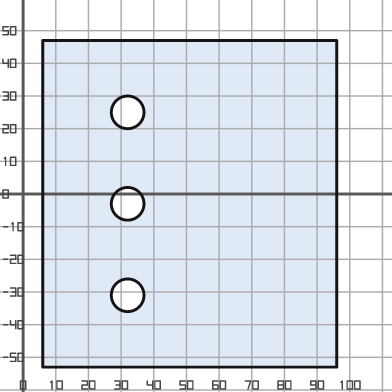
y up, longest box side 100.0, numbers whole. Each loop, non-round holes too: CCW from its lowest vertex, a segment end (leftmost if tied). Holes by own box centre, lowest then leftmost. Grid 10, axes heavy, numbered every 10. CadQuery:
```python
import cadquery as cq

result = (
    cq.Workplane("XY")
    .moveTo(6.0, -53.0)
    .lineTo(96.0, -53.0)
    .lineTo(96.0, 47.0)
    .lineTo(6.0, 47.0)
    .close()
    .moveTo(32.0, -31.0)
    .circle(5.0)
    .moveTo(32.0, -3.0)
    .circle(5.0)
    .moveTo(32.0, 25.0)
    .circle(5.0)
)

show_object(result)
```